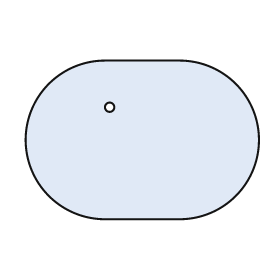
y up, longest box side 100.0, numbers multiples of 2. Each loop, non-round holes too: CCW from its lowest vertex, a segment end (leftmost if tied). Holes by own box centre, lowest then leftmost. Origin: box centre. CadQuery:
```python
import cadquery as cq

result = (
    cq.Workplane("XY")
    .moveTo(-16.0, -34.0)
    .lineTo(16.0, -34.0)
    .threePointArc((50.0, 0.0), (16.0, 34.0))
    .lineTo(-16.0, 34.0)
    .threePointArc((-50.0, 0.0), (-16.0, -34.0))
    .close()
    .moveTo(-14.0, 14.0)
    .circle(2.0)
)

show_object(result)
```